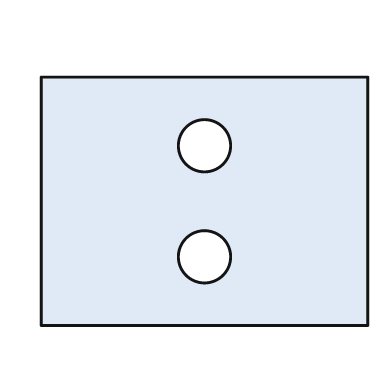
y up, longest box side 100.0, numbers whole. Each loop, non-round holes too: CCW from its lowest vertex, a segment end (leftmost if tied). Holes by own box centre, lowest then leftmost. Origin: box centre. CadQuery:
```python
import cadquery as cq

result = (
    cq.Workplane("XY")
    .moveTo(-50.0, -38.0)
    .lineTo(50.0, -38.0)
    .lineTo(50.0, 38.0)
    .lineTo(-50.0, 38.0)
    .close()
    .moveTo(0.0, -17.0)
    .circle(8.0)
    .moveTo(0.0, 17.0)
    .circle(8.0)
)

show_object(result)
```